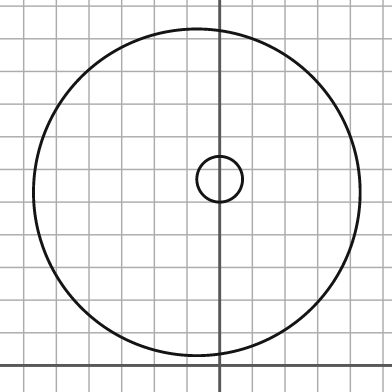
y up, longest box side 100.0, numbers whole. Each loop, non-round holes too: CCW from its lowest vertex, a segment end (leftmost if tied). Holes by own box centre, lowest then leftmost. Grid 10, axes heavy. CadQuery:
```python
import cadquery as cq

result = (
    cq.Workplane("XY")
    .moveTo(-7.0, 53.0)
    .circle(50.0)
    .moveTo(0.0, 57.0)
    .circle(7.0)
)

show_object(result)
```